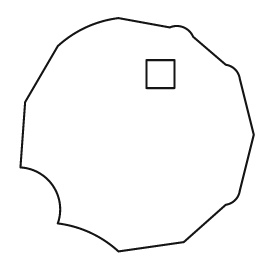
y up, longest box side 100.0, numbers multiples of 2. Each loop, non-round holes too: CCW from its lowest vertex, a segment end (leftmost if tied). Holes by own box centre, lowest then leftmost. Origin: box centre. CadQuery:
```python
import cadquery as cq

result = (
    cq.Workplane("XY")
    .moveTo(-8.0, -50.0)
    .lineTo(20.0, -46.0)
    .lineTo(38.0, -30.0)
    .threePointArc((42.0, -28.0), (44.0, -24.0))
    .lineTo(50.0, 0.0)
    .lineTo(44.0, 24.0)
    .threePointArc((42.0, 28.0), (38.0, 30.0))
    .lineTo(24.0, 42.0)
    .threePointArc((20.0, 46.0), (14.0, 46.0))
    .lineTo(-8.0, 50.0)
    .threePointArc((-22.0, 46.0), (-34.0, 38.0))
    .lineTo(-48.0, 14.0)
    .lineTo(-50.0, -14.0)
    .threePointArc((-36.0, -22.0), (-34.0, -38.0))
    .threePointArc((-20.0, -42.0), (-8.0, -50.0))
    .close()
    .moveTo(4.0, 20.0)
    .lineTo(16.0, 20.0)
    .lineTo(16.0, 32.0)
    .lineTo(4.0, 32.0)
    .close()
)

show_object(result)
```